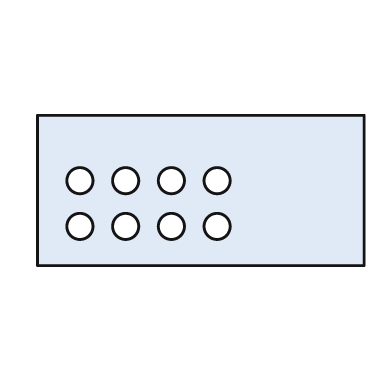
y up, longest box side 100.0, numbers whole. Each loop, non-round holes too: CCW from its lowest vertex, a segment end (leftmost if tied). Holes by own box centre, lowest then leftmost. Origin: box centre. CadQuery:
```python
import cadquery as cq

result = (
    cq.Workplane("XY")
    .moveTo(-50.0, -23.0)
    .lineTo(50.0, -23.0)
    .lineTo(50.0, 23.0)
    .lineTo(-50.0, 23.0)
    .close()
    .moveTo(-37.0, -11.0)
    .circle(4.0)
    .moveTo(-23.0, -11.0)
    .circle(4.0)
    .moveTo(-9.0, -11.0)
    .circle(4.0)
    .moveTo(5.0, -11.0)
    .circle(4.0)
    .moveTo(-37.0, 3.0)
    .circle(4.0)
    .moveTo(-23.0, 3.0)
    .circle(4.0)
    .moveTo(-9.0, 3.0)
    .circle(4.0)
    .moveTo(5.0, 3.0)
    .circle(4.0)
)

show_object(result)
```